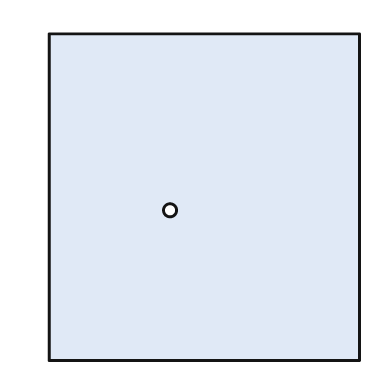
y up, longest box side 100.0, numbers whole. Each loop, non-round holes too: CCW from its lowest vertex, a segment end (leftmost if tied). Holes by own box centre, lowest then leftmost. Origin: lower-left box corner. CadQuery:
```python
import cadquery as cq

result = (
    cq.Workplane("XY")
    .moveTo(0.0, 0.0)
    .lineTo(95.0, 0.0)
    .lineTo(95.0, 100.0)
    .lineTo(0.0, 100.0)
    .close()
    .moveTo(37.0, 46.0)
    .circle(2.0)
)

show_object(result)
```